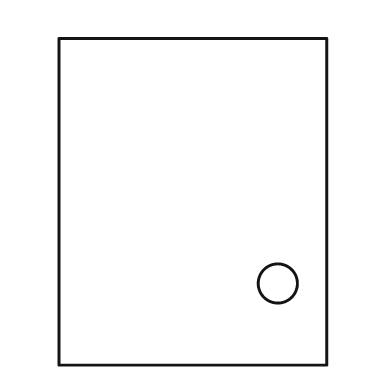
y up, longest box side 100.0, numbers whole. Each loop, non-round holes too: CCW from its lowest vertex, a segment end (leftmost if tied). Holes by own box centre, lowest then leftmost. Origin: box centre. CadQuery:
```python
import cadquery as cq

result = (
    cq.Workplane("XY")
    .moveTo(-41.0, -50.0)
    .lineTo(41.0, -50.0)
    .lineTo(41.0, 50.0)
    .lineTo(-41.0, 50.0)
    .close()
    .moveTo(26.0, -25.0)
    .circle(6.0)
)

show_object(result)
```